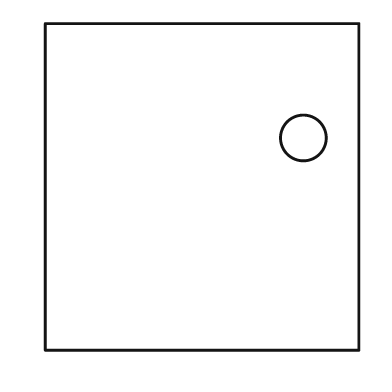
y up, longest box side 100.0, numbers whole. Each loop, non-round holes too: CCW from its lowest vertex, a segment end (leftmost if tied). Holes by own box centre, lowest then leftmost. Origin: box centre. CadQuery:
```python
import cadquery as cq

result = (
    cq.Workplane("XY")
    .moveTo(-48.0, -50.0)
    .lineTo(48.0, -50.0)
    .lineTo(48.0, 50.0)
    .lineTo(-48.0, 50.0)
    .close()
    .moveTo(31.0, 15.0)
    .circle(7.0)
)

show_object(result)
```